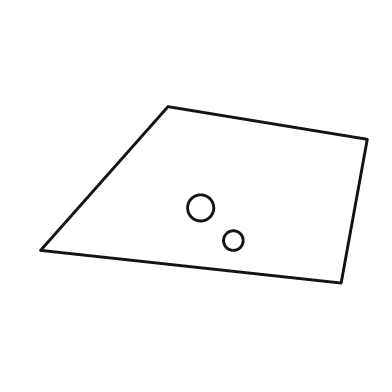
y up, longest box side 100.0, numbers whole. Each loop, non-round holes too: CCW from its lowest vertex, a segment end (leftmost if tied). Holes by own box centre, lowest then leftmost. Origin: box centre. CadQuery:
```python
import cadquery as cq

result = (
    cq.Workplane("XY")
    .moveTo(42.0, -27.0)
    .lineTo(50.0, 17.0)
    .lineTo(-11.0, 27.0)
    .lineTo(-50.0, -17.0)
    .close()
    .moveTo(9.0, -14.0)
    .circle(3.0)
    .moveTo(-1.0, -4.0)
    .circle(4.0)
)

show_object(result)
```